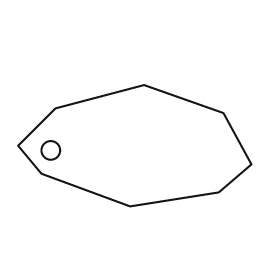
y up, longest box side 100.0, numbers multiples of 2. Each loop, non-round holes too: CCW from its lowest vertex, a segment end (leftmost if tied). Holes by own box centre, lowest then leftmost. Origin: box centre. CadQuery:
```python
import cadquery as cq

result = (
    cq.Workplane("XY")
    .moveTo(-2.0, -26.0)
    .lineTo(36.0, -20.0)
    .lineTo(50.0, -8.0)
    .lineTo(38.0, 14.0)
    .lineTo(4.0, 26.0)
    .lineTo(-34.0, 16.0)
    .lineTo(-50.0, 0.0)
    .lineTo(-40.0, -12.0)
    .close()
    .moveTo(-36.0, -2.0)
    .circle(4.0)
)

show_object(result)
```